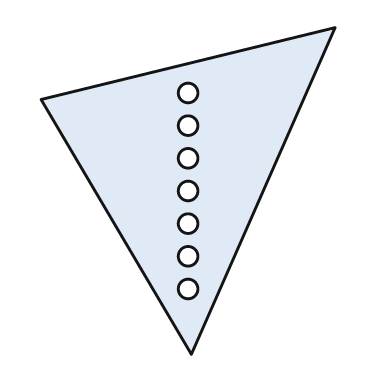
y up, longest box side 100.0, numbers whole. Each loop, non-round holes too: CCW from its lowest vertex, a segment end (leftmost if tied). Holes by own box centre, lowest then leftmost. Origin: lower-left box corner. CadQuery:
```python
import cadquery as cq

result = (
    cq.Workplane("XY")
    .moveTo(46.0, 0.0)
    .lineTo(90.0, 100.0)
    .lineTo(0.0, 78.0)
    .close()
    .moveTo(45.0, 20.0)
    .circle(3.0)
    .moveTo(45.0, 30.0)
    .circle(3.0)
    .moveTo(45.0, 40.0)
    .circle(3.0)
    .moveTo(45.0, 50.0)
    .circle(3.0)
    .moveTo(45.0, 60.0)
    .circle(3.0)
    .moveTo(45.0, 70.0)
    .circle(3.0)
    .moveTo(45.0, 80.0)
    .circle(3.0)
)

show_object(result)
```